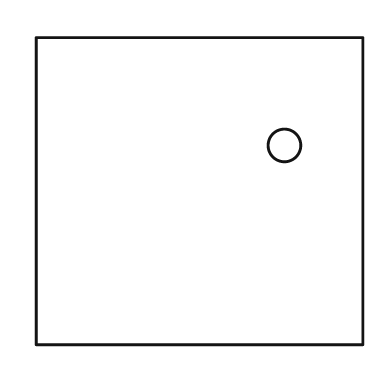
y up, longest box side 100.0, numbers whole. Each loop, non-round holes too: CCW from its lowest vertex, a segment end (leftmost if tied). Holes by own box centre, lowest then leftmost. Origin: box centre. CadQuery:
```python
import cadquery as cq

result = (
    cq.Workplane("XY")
    .moveTo(-50.0, -47.0)
    .lineTo(50.0, -47.0)
    .lineTo(50.0, 47.0)
    .lineTo(-50.0, 47.0)
    .close()
    .moveTo(26.0, 14.0)
    .circle(5.0)
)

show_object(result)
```